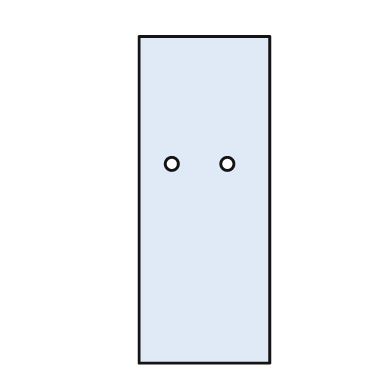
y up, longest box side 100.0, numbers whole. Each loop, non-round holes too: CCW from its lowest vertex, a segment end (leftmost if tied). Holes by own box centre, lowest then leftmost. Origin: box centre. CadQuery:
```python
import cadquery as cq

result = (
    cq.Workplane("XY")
    .moveTo(-20.0, -50.0)
    .lineTo(20.0, -50.0)
    .lineTo(20.0, 50.0)
    .lineTo(-20.0, 50.0)
    .close()
    .moveTo(-10.0, 11.0)
    .circle(2.0)
    .moveTo(7.0, 11.0)
    .circle(2.0)
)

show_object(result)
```